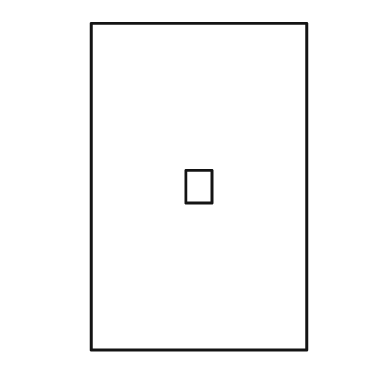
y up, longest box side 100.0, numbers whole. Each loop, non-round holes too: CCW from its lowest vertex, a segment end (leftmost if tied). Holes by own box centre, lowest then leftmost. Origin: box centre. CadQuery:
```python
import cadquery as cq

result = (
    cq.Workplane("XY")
    .moveTo(-33.0, -50.0)
    .lineTo(33.0, -50.0)
    .lineTo(33.0, 50.0)
    .lineTo(-33.0, 50.0)
    .close()
    .moveTo(-4.0, -5.0)
    .lineTo(4.0, -5.0)
    .lineTo(4.0, 5.0)
    .lineTo(-4.0, 5.0)
    .close()
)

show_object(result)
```